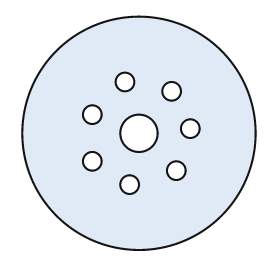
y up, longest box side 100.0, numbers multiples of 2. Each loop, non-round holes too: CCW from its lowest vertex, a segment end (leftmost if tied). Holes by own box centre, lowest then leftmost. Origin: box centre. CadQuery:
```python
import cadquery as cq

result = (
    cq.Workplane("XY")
    .moveTo(0.0, 0.0)
    .circle(50.0)
    .moveTo(-4.0, -22.0)
    .circle(4.0)
    .moveTo(16.0, -16.0)
    .circle(4.0)
    .moveTo(-20.0, -12.0)
    .circle(4.0)
    .moveTo(0.0, 0.0)
    .circle(8.0)
    .moveTo(22.0, 2.0)
    .circle(4.0)
    .moveTo(-20.0, 8.0)
    .circle(4.0)
    .moveTo(14.0, 18.0)
    .circle(4.0)
    .moveTo(-6.0, 22.0)
    .circle(4.0)
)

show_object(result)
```